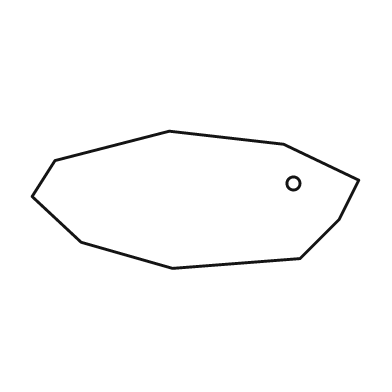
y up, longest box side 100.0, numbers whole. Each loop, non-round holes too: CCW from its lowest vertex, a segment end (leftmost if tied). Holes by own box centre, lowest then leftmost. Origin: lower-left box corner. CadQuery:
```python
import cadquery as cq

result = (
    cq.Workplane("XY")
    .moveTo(43.0, 0.0)
    .lineTo(82.0, 3.0)
    .lineTo(94.0, 15.0)
    .lineTo(100.0, 27.0)
    .lineTo(77.0, 38.0)
    .lineTo(42.0, 42.0)
    .lineTo(7.0, 33.0)
    .lineTo(0.0, 22.0)
    .lineTo(15.0, 8.0)
    .close()
    .moveTo(80.0, 26.0)
    .circle(2.0)
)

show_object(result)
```